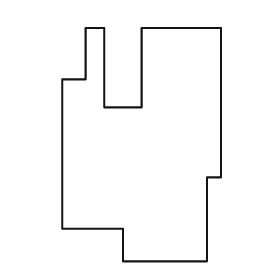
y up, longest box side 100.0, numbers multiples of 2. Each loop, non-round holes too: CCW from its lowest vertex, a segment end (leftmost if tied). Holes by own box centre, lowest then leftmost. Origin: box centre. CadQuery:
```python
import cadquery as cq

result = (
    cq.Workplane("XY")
    .moveTo(-8.0, -50.0)
    .lineTo(28.0, -50.0)
    .lineTo(28.0, -14.0)
    .lineTo(34.0, -14.0)
    .lineTo(34.0, 50.0)
    .lineTo(0.0, 50.0)
    .lineTo(0.0, 16.0)
    .lineTo(-16.0, 16.0)
    .lineTo(-16.0, 50.0)
    .lineTo(-24.0, 50.0)
    .lineTo(-24.0, 28.0)
    .lineTo(-34.0, 28.0)
    .lineTo(-34.0, -36.0)
    .lineTo(-8.0, -36.0)
    .close()
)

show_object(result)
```